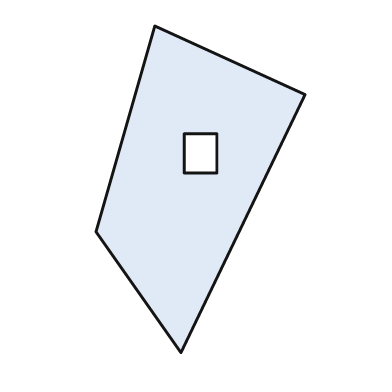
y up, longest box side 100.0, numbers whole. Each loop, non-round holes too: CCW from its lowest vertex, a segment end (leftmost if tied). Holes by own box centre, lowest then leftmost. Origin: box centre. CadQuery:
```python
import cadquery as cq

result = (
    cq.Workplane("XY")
    .moveTo(-6.0, -50.0)
    .lineTo(32.0, 29.0)
    .lineTo(-14.0, 50.0)
    .lineTo(-32.0, -13.0)
    .close()
    .moveTo(-5.0, 5.0)
    .lineTo(5.0, 5.0)
    .lineTo(5.0, 17.0)
    .lineTo(-5.0, 17.0)
    .close()
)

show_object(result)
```